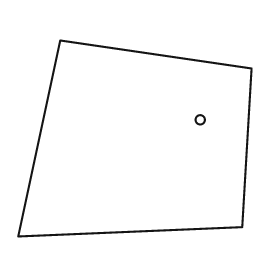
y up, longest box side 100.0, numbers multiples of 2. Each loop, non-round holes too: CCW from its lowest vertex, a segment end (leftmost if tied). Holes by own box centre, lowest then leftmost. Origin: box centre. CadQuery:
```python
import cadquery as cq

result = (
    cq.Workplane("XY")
    .moveTo(-50.0, -42.0)
    .lineTo(46.0, -38.0)
    .lineTo(50.0, 30.0)
    .lineTo(-32.0, 42.0)
    .close()
    .moveTo(28.0, 8.0)
    .circle(2.0)
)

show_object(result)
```